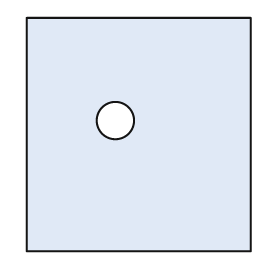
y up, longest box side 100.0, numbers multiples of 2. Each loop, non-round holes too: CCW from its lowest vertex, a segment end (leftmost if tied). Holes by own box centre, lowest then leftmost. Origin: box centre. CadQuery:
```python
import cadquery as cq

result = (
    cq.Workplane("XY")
    .moveTo(-48.0, -50.0)
    .lineTo(48.0, -50.0)
    .lineTo(48.0, 50.0)
    .lineTo(-48.0, 50.0)
    .close()
    .moveTo(-10.0, 6.0)
    .circle(8.0)
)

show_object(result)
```